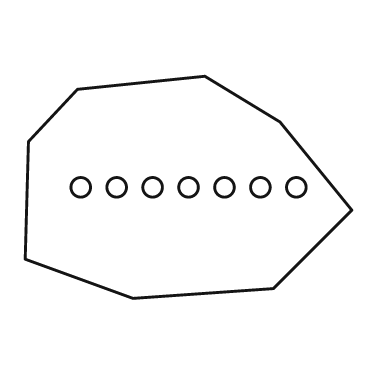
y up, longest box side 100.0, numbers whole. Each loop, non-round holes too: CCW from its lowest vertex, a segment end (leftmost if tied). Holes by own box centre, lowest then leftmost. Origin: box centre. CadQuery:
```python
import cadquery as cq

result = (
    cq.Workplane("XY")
    .moveTo(-17.0, -34.0)
    .lineTo(26.0, -31.0)
    .lineTo(50.0, -7.0)
    .lineTo(28.0, 20.0)
    .lineTo(5.0, 34.0)
    .lineTo(-34.0, 30.0)
    .lineTo(-49.0, 14.0)
    .lineTo(-50.0, -22.0)
    .close()
    .moveTo(-33.0, 0.0)
    .circle(3.0)
    .moveTo(-22.0, 0.0)
    .circle(3.0)
    .moveTo(-11.0, 0.0)
    .circle(3.0)
    .moveTo(0.0, 0.0)
    .circle(3.0)
    .moveTo(11.0, 0.0)
    .circle(3.0)
    .moveTo(22.0, 0.0)
    .circle(3.0)
    .moveTo(33.0, 0.0)
    .circle(3.0)
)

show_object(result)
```